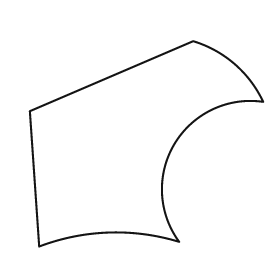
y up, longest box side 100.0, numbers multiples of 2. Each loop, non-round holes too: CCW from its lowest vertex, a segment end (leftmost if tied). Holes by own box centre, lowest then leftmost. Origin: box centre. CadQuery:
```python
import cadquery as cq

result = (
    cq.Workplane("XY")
    .moveTo(-46.0, -44.0)
    .threePointArc((-16.0, -38.0), (14.0, -42.0))
    .threePointArc((12.0, 0.0), (50.0, 18.0))
    .threePointArc((38.0, 34.0), (20.0, 44.0))
    .lineTo(-50.0, 14.0)
    .close()
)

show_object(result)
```